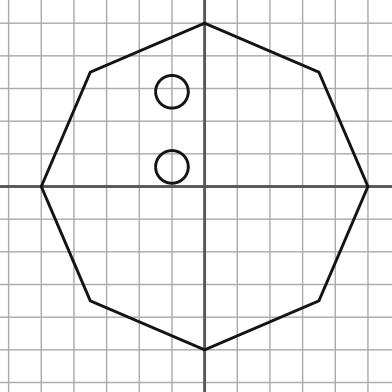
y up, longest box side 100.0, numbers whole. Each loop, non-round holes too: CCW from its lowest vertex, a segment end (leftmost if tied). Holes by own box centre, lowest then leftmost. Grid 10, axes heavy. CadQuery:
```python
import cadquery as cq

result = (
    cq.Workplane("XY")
    .moveTo(0.0, -50.0)
    .lineTo(35.0, -35.0)
    .lineTo(50.0, 0.0)
    .lineTo(35.0, 35.0)
    .lineTo(0.0, 50.0)
    .lineTo(-35.0, 35.0)
    .lineTo(-50.0, 0.0)
    .lineTo(-35.0, -35.0)
    .close()
    .moveTo(-10.0, 6.0)
    .circle(5.0)
    .moveTo(-10.0, 29.0)
    .circle(5.0)
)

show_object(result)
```